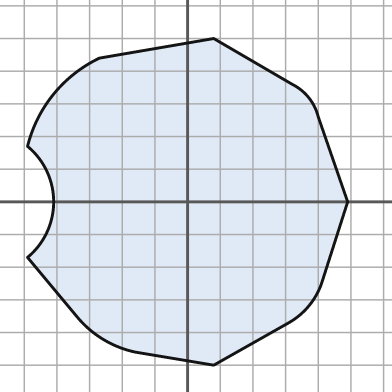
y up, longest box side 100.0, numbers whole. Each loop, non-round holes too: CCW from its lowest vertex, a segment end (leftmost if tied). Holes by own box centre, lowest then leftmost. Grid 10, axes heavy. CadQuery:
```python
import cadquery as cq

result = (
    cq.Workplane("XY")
    .moveTo(8.0, -50.0)
    .lineTo(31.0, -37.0)
    .threePointArc((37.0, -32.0), (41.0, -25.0))
    .lineTo(49.0, 0.0)
    .lineTo(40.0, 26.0)
    .threePointArc((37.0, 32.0), (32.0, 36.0))
    .lineTo(8.0, 50.0)
    .lineTo(-27.0, 44.0)
    .threePointArc((-41.0, 33.0), (-49.0, 17.0))
    .threePointArc((-41.0, 0.0), (-49.0, -17.0))
    .lineTo(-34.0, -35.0)
    .threePointArc((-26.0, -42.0), (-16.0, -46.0))
    .close()
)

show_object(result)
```